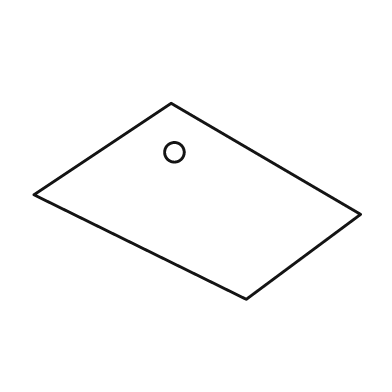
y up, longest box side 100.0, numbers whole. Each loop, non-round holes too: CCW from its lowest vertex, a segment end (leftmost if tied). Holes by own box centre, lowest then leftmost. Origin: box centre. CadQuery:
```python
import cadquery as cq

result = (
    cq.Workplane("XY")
    .moveTo(15.0, -30.0)
    .lineTo(50.0, -4.0)
    .lineTo(-8.0, 30.0)
    .lineTo(-50.0, 2.0)
    .close()
    .moveTo(-7.0, 15.0)
    .circle(3.0)
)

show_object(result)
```